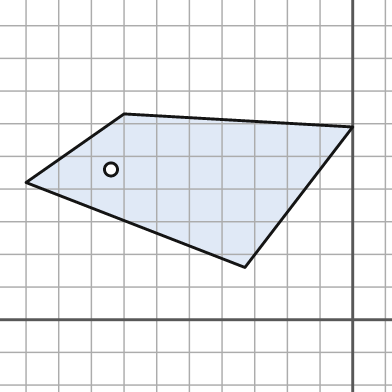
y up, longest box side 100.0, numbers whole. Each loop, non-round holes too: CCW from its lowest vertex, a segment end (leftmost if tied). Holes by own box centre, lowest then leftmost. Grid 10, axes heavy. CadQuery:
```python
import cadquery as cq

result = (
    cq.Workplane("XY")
    .moveTo(-33.0, 16.0)
    .lineTo(0.0, 59.0)
    .lineTo(-70.0, 63.0)
    .lineTo(-100.0, 42.0)
    .close()
    .moveTo(-74.0, 46.0)
    .circle(2.0)
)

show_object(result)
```